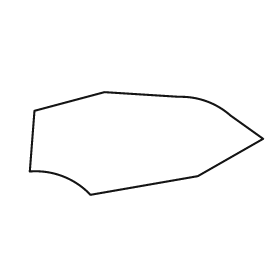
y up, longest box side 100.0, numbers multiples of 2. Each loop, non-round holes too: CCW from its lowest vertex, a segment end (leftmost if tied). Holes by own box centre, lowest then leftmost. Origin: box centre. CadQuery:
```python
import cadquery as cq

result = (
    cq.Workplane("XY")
    .moveTo(-24.0, -22.0)
    .lineTo(22.0, -14.0)
    .lineTo(50.0, 2.0)
    .lineTo(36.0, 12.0)
    .threePointArc((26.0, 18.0), (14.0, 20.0))
    .lineTo(-18.0, 22.0)
    .lineTo(-48.0, 14.0)
    .lineTo(-50.0, -12.0)
    .threePointArc((-36.0, -14.0), (-24.0, -22.0))
    .close()
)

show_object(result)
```